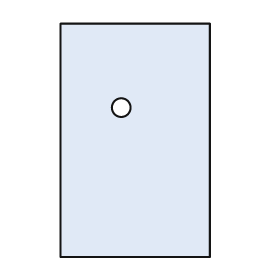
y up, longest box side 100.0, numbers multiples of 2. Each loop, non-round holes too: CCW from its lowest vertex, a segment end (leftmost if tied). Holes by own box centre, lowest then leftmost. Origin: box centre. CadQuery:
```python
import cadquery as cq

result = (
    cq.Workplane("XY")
    .moveTo(-32.0, -50.0)
    .lineTo(32.0, -50.0)
    .lineTo(32.0, 50.0)
    .lineTo(-32.0, 50.0)
    .close()
    .moveTo(-6.0, 14.0)
    .circle(4.0)
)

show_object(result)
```